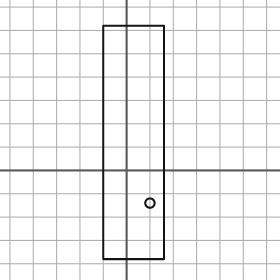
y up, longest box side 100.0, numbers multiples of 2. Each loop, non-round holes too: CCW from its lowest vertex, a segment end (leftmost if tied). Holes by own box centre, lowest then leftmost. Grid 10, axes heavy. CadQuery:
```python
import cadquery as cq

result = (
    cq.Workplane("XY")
    .moveTo(-10.0, -38.0)
    .lineTo(16.0, -38.0)
    .lineTo(16.0, 62.0)
    .lineTo(-10.0, 62.0)
    .close()
    .moveTo(10.0, -14.0)
    .circle(2.0)
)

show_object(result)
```